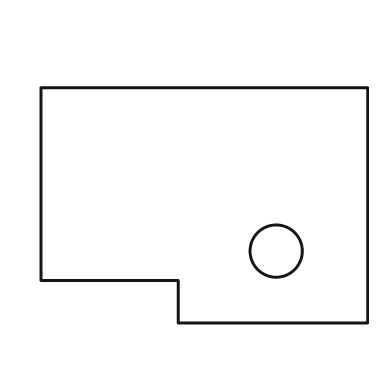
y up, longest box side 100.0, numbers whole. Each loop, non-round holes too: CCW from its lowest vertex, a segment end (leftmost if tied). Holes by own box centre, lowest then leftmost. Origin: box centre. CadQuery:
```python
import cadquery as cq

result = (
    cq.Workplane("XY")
    .moveTo(-8.0, -36.0)
    .lineTo(50.0, -36.0)
    .lineTo(50.0, 36.0)
    .lineTo(-50.0, 36.0)
    .lineTo(-50.0, -23.0)
    .lineTo(-8.0, -23.0)
    .close()
    .moveTo(22.0, -14.0)
    .circle(8.0)
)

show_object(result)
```